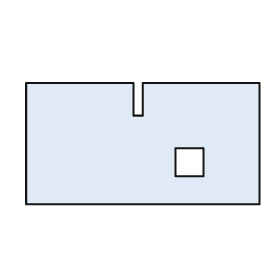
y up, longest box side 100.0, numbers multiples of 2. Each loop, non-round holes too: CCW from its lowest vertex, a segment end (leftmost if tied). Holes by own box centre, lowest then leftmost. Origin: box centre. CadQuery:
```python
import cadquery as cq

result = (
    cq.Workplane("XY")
    .moveTo(-50.0, -26.0)
    .lineTo(50.0, -26.0)
    .lineTo(50.0, 26.0)
    .lineTo(0.0, 26.0)
    .lineTo(0.0, 12.0)
    .lineTo(-4.0, 12.0)
    .lineTo(-4.0, 26.0)
    .lineTo(-50.0, 26.0)
    .close()
    .moveTo(14.0, -14.0)
    .lineTo(26.0, -14.0)
    .lineTo(26.0, -2.0)
    .lineTo(14.0, -2.0)
    .close()
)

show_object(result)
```